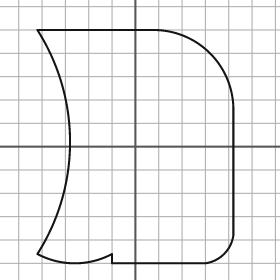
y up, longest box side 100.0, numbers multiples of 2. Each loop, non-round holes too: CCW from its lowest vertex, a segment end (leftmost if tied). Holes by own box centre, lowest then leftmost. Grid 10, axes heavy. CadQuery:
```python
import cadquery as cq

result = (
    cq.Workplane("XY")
    .moveTo(-10.0, -50.0)
    .lineTo(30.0, -50.0)
    .threePointArc((38.0, -46.0), (42.0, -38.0))
    .lineTo(42.0, 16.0)
    .threePointArc((32.0, 40.0), (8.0, 50.0))
    .lineTo(-42.0, 50.0)
    .threePointArc((-28.0, 2.0), (-42.0, -46.0))
    .threePointArc((-26.0, -50.0), (-10.0, -46.0))
    .close()
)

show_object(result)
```